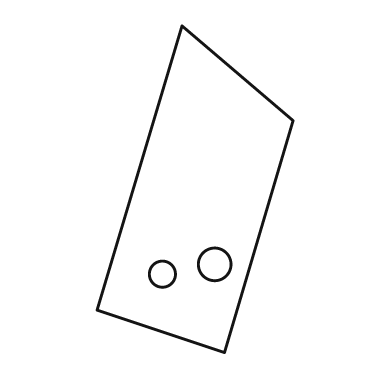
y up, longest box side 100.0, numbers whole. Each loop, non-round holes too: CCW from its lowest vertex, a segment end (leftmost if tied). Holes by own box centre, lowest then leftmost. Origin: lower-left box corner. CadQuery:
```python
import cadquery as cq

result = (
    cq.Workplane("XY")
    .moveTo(39.0, 0.0)
    .lineTo(60.0, 71.0)
    .lineTo(26.0, 100.0)
    .lineTo(0.0, 13.0)
    .close()
    .moveTo(20.0, 24.0)
    .circle(4.0)
    .moveTo(36.0, 27.0)
    .circle(5.0)
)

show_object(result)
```